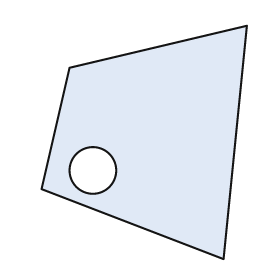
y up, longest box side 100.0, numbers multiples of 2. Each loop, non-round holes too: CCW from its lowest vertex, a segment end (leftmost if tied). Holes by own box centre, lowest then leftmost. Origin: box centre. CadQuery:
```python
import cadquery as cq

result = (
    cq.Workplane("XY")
    .moveTo(34.0, -50.0)
    .lineTo(44.0, 50.0)
    .lineTo(-32.0, 32.0)
    .lineTo(-44.0, -20.0)
    .close()
    .moveTo(-22.0, -12.0)
    .circle(10.0)
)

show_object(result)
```